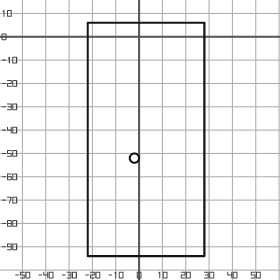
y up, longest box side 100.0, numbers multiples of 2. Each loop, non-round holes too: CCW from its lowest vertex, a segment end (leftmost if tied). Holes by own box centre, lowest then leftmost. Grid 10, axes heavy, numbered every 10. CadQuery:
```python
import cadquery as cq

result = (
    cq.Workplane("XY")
    .moveTo(-22.0, -94.0)
    .lineTo(28.0, -94.0)
    .lineTo(28.0, 6.0)
    .lineTo(-22.0, 6.0)
    .close()
    .moveTo(-2.0, -52.0)
    .circle(2.0)
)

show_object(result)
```